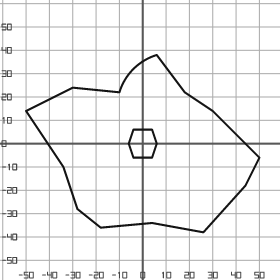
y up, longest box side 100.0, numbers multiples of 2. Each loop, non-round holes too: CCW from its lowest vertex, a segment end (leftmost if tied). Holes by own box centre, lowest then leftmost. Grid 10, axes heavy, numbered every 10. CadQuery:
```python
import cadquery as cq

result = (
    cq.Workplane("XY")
    .moveTo(26.0, -38.0)
    .lineTo(44.0, -18.0)
    .lineTo(50.0, -6.0)
    .lineTo(30.0, 14.0)
    .lineTo(18.0, 22.0)
    .lineTo(6.0, 38.0)
    .threePointArc((-4.0, 32.0), (-10.0, 22.0))
    .lineTo(-30.0, 24.0)
    .lineTo(-50.0, 14.0)
    .lineTo(-34.0, -10.0)
    .lineTo(-28.0, -28.0)
    .lineTo(-18.0, -36.0)
    .lineTo(4.0, -34.0)
    .close()
    .moveTo(-4.0, -6.0)
    .lineTo(4.0, -6.0)
    .lineTo(6.0, 0.0)
    .lineTo(4.0, 6.0)
    .lineTo(-4.0, 6.0)
    .lineTo(-6.0, 0.0)
    .close()
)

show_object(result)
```